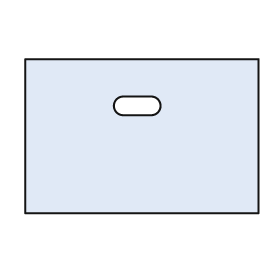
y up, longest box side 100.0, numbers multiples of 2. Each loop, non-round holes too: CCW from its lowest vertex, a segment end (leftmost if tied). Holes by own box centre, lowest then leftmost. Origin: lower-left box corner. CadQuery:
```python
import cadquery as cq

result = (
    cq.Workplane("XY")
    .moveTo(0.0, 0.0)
    .lineTo(100.0, 0.0)
    .lineTo(100.0, 66.0)
    .lineTo(0.0, 66.0)
    .close()
    .moveTo(42.0, 42.0)
    .lineTo(54.0, 42.0)
    .threePointArc((58.0, 46.0), (54.0, 50.0))
    .lineTo(42.0, 50.0)
    .threePointArc((38.0, 46.0), (42.0, 42.0))
    .close()
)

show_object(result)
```